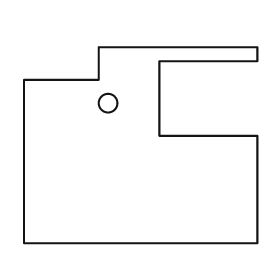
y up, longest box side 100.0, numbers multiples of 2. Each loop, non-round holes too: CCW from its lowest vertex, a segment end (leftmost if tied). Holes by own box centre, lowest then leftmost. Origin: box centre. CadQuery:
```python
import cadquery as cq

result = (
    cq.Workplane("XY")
    .moveTo(-50.0, -42.0)
    .lineTo(50.0, -42.0)
    .lineTo(50.0, 4.0)
    .lineTo(8.0, 4.0)
    .lineTo(8.0, 36.0)
    .lineTo(50.0, 36.0)
    .lineTo(50.0, 42.0)
    .lineTo(-18.0, 42.0)
    .lineTo(-18.0, 28.0)
    .lineTo(-50.0, 28.0)
    .close()
    .moveTo(-14.0, 18.0)
    .circle(4.0)
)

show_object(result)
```